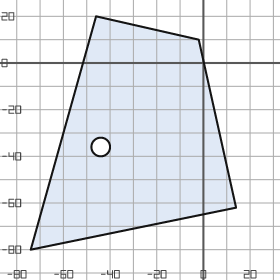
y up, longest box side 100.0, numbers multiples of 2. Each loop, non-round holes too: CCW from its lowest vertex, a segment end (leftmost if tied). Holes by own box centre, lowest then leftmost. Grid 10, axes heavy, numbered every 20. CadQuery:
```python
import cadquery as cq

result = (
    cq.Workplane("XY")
    .moveTo(-74.0, -80.0)
    .lineTo(14.0, -62.0)
    .lineTo(-2.0, 10.0)
    .lineTo(-46.0, 20.0)
    .close()
    .moveTo(-44.0, -36.0)
    .circle(4.0)
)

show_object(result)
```